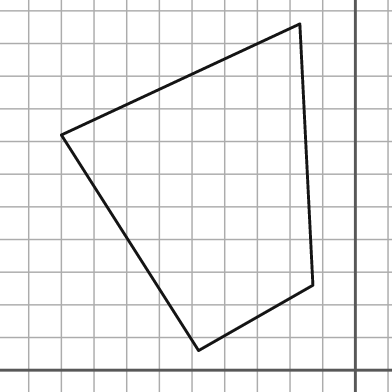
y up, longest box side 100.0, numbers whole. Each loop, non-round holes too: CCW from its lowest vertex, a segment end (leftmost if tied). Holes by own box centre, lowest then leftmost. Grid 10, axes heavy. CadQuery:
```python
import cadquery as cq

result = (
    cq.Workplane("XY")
    .moveTo(-48.0, 6.0)
    .lineTo(-13.0, 26.0)
    .lineTo(-17.0, 106.0)
    .lineTo(-90.0, 72.0)
    .close()
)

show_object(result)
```